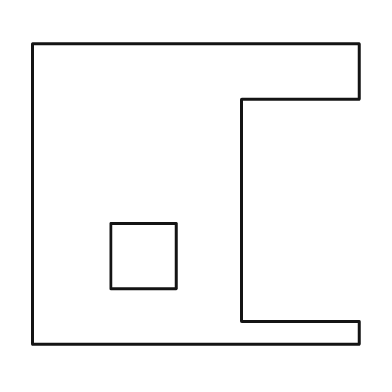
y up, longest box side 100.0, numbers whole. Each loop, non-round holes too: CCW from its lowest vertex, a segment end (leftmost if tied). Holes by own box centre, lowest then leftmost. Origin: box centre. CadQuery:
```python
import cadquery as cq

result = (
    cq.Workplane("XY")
    .moveTo(-50.0, -46.0)
    .lineTo(50.0, -46.0)
    .lineTo(50.0, -39.0)
    .lineTo(14.0, -39.0)
    .lineTo(14.0, 29.0)
    .lineTo(50.0, 29.0)
    .lineTo(50.0, 46.0)
    .lineTo(-50.0, 46.0)
    .close()
    .moveTo(-26.0, -29.0)
    .lineTo(-6.0, -29.0)
    .lineTo(-6.0, -9.0)
    .lineTo(-26.0, -9.0)
    .close()
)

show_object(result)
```